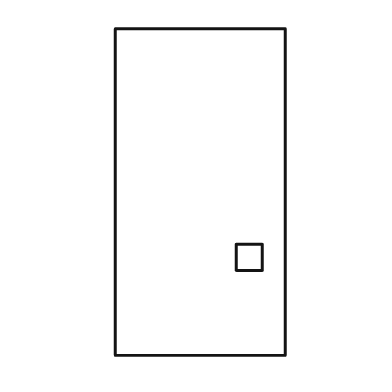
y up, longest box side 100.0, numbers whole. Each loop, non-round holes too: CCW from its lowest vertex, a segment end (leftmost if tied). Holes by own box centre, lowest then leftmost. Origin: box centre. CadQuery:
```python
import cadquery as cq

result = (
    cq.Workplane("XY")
    .moveTo(-26.0, -50.0)
    .lineTo(26.0, -50.0)
    .lineTo(26.0, 50.0)
    .lineTo(-26.0, 50.0)
    .close()
    .moveTo(11.0, -24.0)
    .lineTo(19.0, -24.0)
    .lineTo(19.0, -16.0)
    .lineTo(11.0, -16.0)
    .close()
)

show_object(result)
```